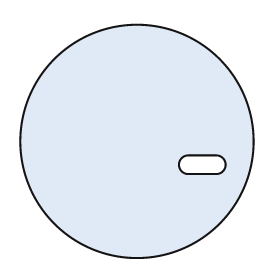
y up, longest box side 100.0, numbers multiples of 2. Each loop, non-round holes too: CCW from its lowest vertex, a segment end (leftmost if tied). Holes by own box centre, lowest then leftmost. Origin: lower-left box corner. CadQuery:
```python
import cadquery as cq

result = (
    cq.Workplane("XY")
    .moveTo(50.0, 50.0)
    .circle(50.0)
    .moveTo(72.0, 36.0)
    .lineTo(84.0, 36.0)
    .threePointArc((88.0, 40.0), (84.0, 44.0))
    .lineTo(72.0, 44.0)
    .threePointArc((68.0, 40.0), (72.0, 36.0))
    .close()
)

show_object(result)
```